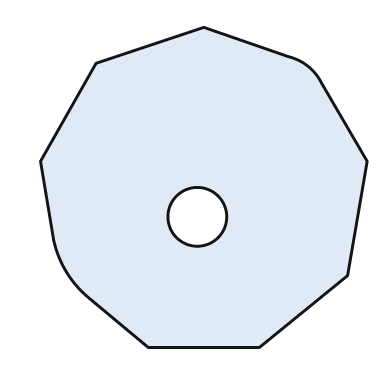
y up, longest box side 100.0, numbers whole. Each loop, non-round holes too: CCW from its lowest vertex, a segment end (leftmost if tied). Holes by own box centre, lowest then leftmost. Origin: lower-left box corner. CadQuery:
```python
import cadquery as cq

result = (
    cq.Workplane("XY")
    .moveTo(33.0, 0.0)
    .lineTo(67.0, 0.0)
    .lineTo(94.0, 22.0)
    .lineTo(100.0, 57.0)
    .lineTo(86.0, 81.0)
    .threePointArc((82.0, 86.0), (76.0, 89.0))
    .lineTo(50.0, 98.0)
    .lineTo(17.0, 87.0)
    .lineTo(0.0, 57.0)
    .lineTo(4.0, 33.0)
    .threePointArc((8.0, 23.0), (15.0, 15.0))
    .close()
    .moveTo(48.0, 40.0)
    .circle(9.0)
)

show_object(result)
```